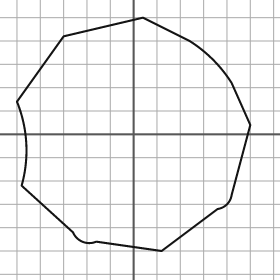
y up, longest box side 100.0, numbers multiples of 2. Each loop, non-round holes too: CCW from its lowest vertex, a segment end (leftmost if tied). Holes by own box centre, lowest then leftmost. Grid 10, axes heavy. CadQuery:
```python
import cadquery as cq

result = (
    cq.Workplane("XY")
    .moveTo(12.0, -50.0)
    .lineTo(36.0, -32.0)
    .threePointArc((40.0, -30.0), (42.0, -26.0))
    .lineTo(50.0, 4.0)
    .lineTo(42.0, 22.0)
    .threePointArc((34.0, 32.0), (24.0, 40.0))
    .lineTo(4.0, 50.0)
    .lineTo(-30.0, 42.0)
    .lineTo(-50.0, 14.0)
    .threePointArc((-46.0, -4.0), (-48.0, -22.0))
    .lineTo(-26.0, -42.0)
    .threePointArc((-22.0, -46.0), (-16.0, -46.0))
    .close()
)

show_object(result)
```